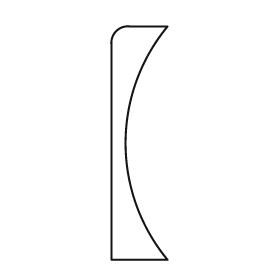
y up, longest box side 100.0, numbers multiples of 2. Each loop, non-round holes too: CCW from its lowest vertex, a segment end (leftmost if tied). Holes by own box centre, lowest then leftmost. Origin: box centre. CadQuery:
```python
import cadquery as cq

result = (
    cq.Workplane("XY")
    .moveTo(-12.0, -50.0)
    .lineTo(12.0, -50.0)
    .threePointArc((-6.0, 0.0), (12.0, 50.0))
    .lineTo(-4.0, 50.0)
    .threePointArc((-10.0, 48.0), (-12.0, 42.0))
    .close()
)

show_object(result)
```